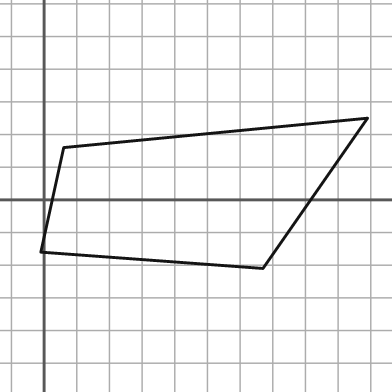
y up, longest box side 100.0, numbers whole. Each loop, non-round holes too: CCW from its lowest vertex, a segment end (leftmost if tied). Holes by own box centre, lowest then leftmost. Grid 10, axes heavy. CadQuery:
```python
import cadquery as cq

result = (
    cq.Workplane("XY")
    .moveTo(67.0, -21.0)
    .lineTo(99.0, 25.0)
    .lineTo(6.0, 16.0)
    .lineTo(-1.0, -16.0)
    .close()
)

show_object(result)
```